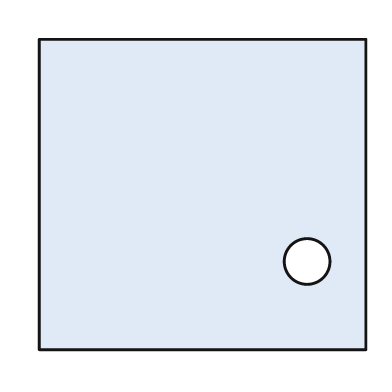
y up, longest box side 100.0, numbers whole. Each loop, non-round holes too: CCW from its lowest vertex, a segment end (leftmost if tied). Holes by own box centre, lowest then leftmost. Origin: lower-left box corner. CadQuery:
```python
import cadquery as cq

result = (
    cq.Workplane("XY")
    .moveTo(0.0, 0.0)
    .lineTo(100.0, 0.0)
    .lineTo(100.0, 95.0)
    .lineTo(0.0, 95.0)
    .close()
    .moveTo(82.0, 27.0)
    .circle(7.0)
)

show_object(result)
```